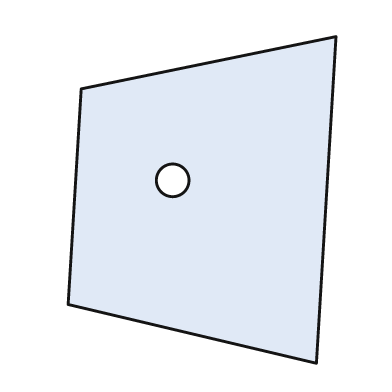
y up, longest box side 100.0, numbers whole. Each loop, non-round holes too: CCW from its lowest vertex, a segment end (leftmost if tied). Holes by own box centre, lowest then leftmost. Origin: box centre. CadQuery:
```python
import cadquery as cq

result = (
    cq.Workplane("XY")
    .moveTo(35.0, -50.0)
    .lineTo(41.0, 50.0)
    .lineTo(-37.0, 34.0)
    .lineTo(-41.0, -32.0)
    .close()
    .moveTo(-9.0, 6.0)
    .circle(5.0)
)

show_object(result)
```